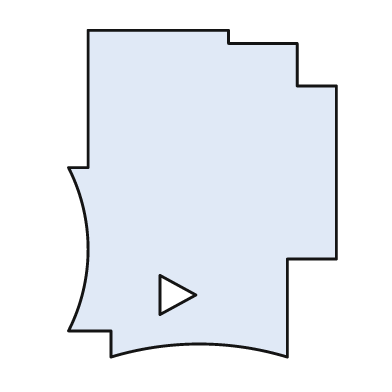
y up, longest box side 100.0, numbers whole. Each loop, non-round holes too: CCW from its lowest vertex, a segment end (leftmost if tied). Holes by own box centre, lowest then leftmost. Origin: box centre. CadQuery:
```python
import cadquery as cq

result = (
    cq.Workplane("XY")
    .moveTo(-28.0, -50.0)
    .threePointArc((-1.0, -46.0), (26.0, -50.0))
    .lineTo(26.0, -20.0)
    .lineTo(41.0, -20.0)
    .lineTo(41.0, 33.0)
    .lineTo(29.0, 33.0)
    .lineTo(29.0, 46.0)
    .lineTo(8.0, 46.0)
    .lineTo(8.0, 50.0)
    .lineTo(-35.0, 50.0)
    .lineTo(-35.0, 8.0)
    .lineTo(-41.0, 8.0)
    .threePointArc((-35.0, -17.0), (-41.0, -42.0))
    .lineTo(-28.0, -42.0)
    .close()
    .moveTo(-13.0, -37.0)
    .lineTo(-2.0, -31.0)
    .lineTo(-13.0, -25.0)
    .close()
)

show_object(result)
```